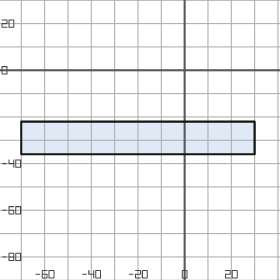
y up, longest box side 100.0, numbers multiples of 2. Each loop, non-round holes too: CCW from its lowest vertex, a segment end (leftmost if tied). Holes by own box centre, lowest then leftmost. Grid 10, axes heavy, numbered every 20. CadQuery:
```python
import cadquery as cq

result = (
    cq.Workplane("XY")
    .moveTo(-70.0, -36.0)
    .lineTo(30.0, -36.0)
    .lineTo(30.0, -22.0)
    .lineTo(-70.0, -22.0)
    .close()
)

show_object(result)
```